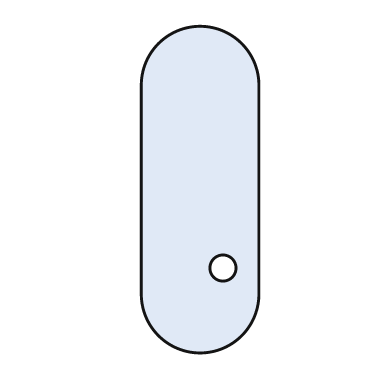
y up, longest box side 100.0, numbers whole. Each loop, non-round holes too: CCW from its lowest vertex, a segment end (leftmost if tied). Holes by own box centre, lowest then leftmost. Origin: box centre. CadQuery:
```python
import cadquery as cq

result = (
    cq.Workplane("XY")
    .moveTo(-18.0, -32.0)
    .threePointArc((0.0, -50.0), (18.0, -32.0))
    .lineTo(18.0, 32.0)
    .threePointArc((0.0, 50.0), (-18.0, 32.0))
    .close()
    .moveTo(7.0, -24.0)
    .circle(4.0)
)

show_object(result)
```